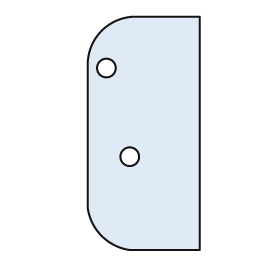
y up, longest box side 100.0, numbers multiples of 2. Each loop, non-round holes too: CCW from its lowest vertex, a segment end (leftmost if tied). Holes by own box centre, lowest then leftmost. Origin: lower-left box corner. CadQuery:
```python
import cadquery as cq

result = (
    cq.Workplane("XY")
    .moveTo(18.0, 0.0)
    .lineTo(48.0, 0.0)
    .lineTo(48.0, 100.0)
    .lineTo(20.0, 100.0)
    .threePointArc((6.0, 94.0), (0.0, 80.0))
    .lineTo(0.0, 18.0)
    .threePointArc((6.0, 6.0), (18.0, 0.0))
    .close()
    .moveTo(18.0, 40.0)
    .circle(4.0)
    .moveTo(8.0, 78.0)
    .circle(4.0)
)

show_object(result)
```